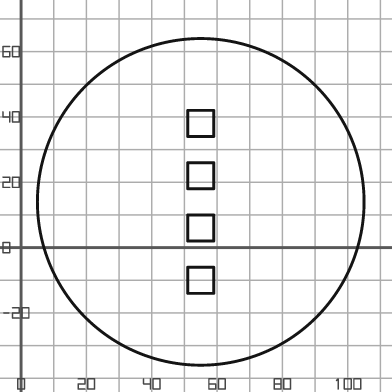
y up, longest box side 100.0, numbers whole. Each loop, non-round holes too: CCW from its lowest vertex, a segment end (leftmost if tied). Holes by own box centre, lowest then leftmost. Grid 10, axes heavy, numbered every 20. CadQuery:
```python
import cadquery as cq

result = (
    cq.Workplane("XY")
    .moveTo(55.0, 14.0)
    .circle(50.0)
    .moveTo(51.0, -14.0)
    .lineTo(59.0, -14.0)
    .lineTo(59.0, -6.0)
    .lineTo(51.0, -6.0)
    .close()
    .moveTo(51.0, 2.0)
    .lineTo(59.0, 2.0)
    .lineTo(59.0, 10.0)
    .lineTo(51.0, 10.0)
    .close()
    .moveTo(51.0, 18.0)
    .lineTo(59.0, 18.0)
    .lineTo(59.0, 26.0)
    .lineTo(51.0, 26.0)
    .close()
    .moveTo(51.0, 34.0)
    .lineTo(59.0, 34.0)
    .lineTo(59.0, 42.0)
    .lineTo(51.0, 42.0)
    .close()
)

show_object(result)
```